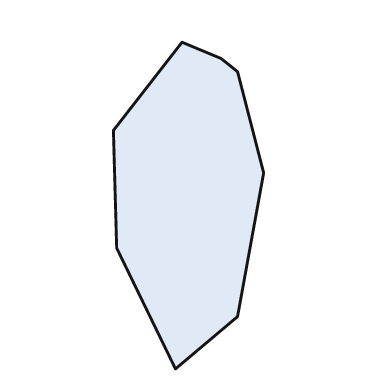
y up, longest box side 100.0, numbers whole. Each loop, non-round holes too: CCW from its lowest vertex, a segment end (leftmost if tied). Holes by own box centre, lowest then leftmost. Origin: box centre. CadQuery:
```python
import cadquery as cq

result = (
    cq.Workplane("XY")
    .moveTo(-4.0, -50.0)
    .lineTo(15.0, -34.0)
    .lineTo(23.0, 10.0)
    .lineTo(15.0, 41.0)
    .lineTo(10.0, 45.0)
    .lineTo(-2.0, 50.0)
    .lineTo(-23.0, 23.0)
    .lineTo(-22.0, -13.0)
    .close()
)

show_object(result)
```